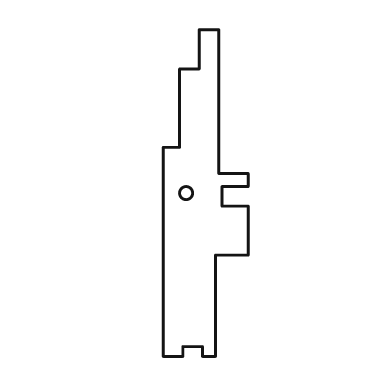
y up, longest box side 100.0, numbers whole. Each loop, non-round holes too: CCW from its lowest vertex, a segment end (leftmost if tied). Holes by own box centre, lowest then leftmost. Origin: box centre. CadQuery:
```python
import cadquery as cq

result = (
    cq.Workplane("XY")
    .moveTo(-13.0, -50.0)
    .lineTo(-7.0, -50.0)
    .lineTo(-7.0, -47.0)
    .lineTo(-1.0, -47.0)
    .lineTo(-1.0, -50.0)
    .lineTo(3.0, -50.0)
    .lineTo(3.0, -19.0)
    .lineTo(13.0, -19.0)
    .lineTo(13.0, -4.0)
    .lineTo(5.0, -4.0)
    .lineTo(5.0, 2.0)
    .lineTo(13.0, 2.0)
    .lineTo(13.0, 6.0)
    .lineTo(4.0, 6.0)
    .lineTo(4.0, 50.0)
    .lineTo(-2.0, 50.0)
    .lineTo(-2.0, 38.0)
    .lineTo(-8.0, 38.0)
    .lineTo(-8.0, 14.0)
    .lineTo(-13.0, 14.0)
    .close()
    .moveTo(-6.0, 0.0)
    .circle(2.0)
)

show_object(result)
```